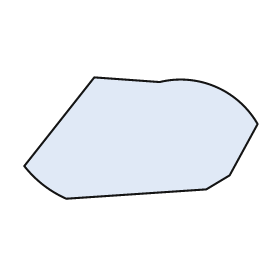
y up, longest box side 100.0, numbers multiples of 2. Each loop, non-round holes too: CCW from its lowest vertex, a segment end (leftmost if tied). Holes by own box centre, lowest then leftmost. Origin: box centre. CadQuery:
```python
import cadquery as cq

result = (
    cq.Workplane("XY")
    .moveTo(-32.0, -26.0)
    .lineTo(28.0, -22.0)
    .lineTo(38.0, -16.0)
    .lineTo(50.0, 6.0)
    .threePointArc((32.0, 22.0), (8.0, 24.0))
    .lineTo(-20.0, 26.0)
    .lineTo(-50.0, -12.0)
    .threePointArc((-42.0, -20.0), (-32.0, -26.0))
    .close()
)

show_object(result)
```